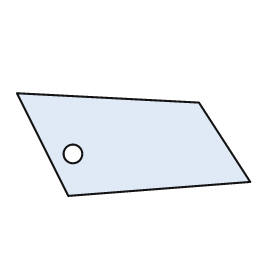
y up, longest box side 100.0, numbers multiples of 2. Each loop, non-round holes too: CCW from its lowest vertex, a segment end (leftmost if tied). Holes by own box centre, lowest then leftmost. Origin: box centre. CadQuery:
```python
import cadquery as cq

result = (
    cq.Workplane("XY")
    .moveTo(-28.0, -22.0)
    .lineTo(50.0, -16.0)
    .lineTo(28.0, 18.0)
    .lineTo(-50.0, 22.0)
    .close()
    .moveTo(-26.0, -4.0)
    .circle(4.0)
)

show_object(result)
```